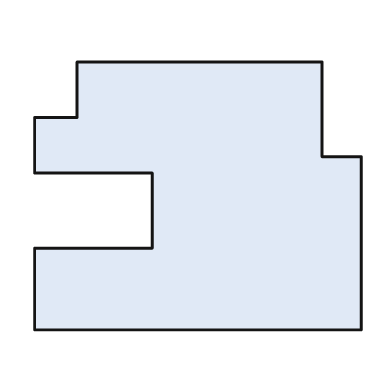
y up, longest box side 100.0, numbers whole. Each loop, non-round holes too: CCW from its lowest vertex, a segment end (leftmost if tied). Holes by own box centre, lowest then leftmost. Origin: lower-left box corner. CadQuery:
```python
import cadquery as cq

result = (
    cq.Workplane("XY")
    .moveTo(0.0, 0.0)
    .lineTo(100.0, 0.0)
    .lineTo(100.0, 53.0)
    .lineTo(88.0, 53.0)
    .lineTo(88.0, 82.0)
    .lineTo(13.0, 82.0)
    .lineTo(13.0, 65.0)
    .lineTo(0.0, 65.0)
    .lineTo(0.0, 48.0)
    .lineTo(36.0, 48.0)
    .lineTo(36.0, 25.0)
    .lineTo(0.0, 25.0)
    .close()
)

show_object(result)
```